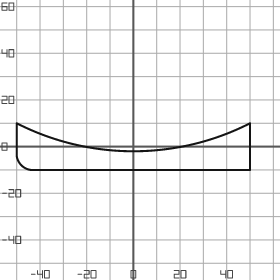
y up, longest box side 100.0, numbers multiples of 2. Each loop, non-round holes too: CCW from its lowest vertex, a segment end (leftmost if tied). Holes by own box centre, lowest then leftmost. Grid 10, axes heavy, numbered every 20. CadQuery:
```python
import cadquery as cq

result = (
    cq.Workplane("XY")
    .moveTo(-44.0, -10.0)
    .lineTo(50.0, -10.0)
    .lineTo(50.0, 10.0)
    .threePointArc((0.0, -2.0), (-50.0, 10.0))
    .lineTo(-50.0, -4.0)
    .threePointArc((-48.0, -8.0), (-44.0, -10.0))
    .close()
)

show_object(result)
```